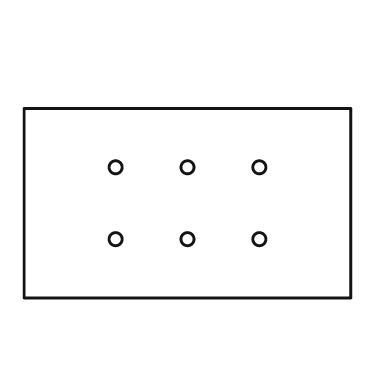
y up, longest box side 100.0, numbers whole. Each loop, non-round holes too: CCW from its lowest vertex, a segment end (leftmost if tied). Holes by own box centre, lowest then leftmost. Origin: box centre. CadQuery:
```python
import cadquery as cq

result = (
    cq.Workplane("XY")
    .moveTo(-50.0, -29.0)
    .lineTo(50.0, -29.0)
    .lineTo(50.0, 29.0)
    .lineTo(-50.0, 29.0)
    .close()
    .moveTo(-22.0, -11.0)
    .circle(2.0)
    .moveTo(0.0, -11.0)
    .circle(2.0)
    .moveTo(22.0, -11.0)
    .circle(2.0)
    .moveTo(-22.0, 11.0)
    .circle(2.0)
    .moveTo(0.0, 11.0)
    .circle(2.0)
    .moveTo(22.0, 11.0)
    .circle(2.0)
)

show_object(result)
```